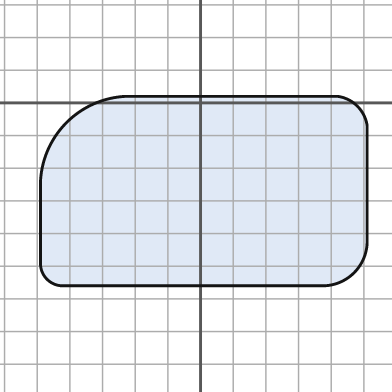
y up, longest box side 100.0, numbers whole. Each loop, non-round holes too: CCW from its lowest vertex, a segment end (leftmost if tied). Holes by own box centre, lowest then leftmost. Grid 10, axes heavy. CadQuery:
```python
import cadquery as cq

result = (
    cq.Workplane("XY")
    .moveTo(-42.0, -56.0)
    .lineTo(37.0, -56.0)
    .threePointArc((47.0, -52.0), (51.0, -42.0))
    .lineTo(51.0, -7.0)
    .threePointArc((48.0, -1.0), (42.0, 2.0))
    .lineTo(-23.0, 2.0)
    .threePointArc((-41.0, -6.0), (-49.0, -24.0))
    .lineTo(-49.0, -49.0)
    .threePointArc((-47.0, -54.0), (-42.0, -56.0))
    .close()
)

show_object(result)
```